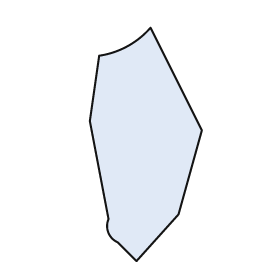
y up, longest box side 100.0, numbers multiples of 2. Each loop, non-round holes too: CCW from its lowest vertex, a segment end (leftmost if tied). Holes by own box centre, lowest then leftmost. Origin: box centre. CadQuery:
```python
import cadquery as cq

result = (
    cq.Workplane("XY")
    .moveTo(-4.0, -50.0)
    .lineTo(14.0, -30.0)
    .lineTo(24.0, 6.0)
    .lineTo(2.0, 50.0)
    .threePointArc((-8.0, 42.0), (-20.0, 38.0))
    .lineTo(-24.0, 10.0)
    .lineTo(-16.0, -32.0)
    .threePointArc((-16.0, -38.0), (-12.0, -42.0))
    .close()
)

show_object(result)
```